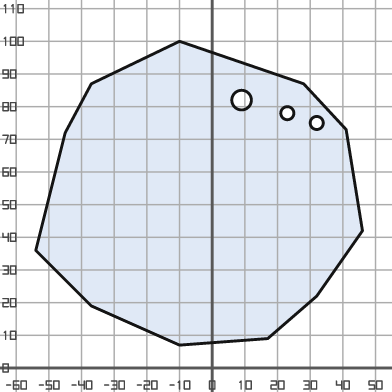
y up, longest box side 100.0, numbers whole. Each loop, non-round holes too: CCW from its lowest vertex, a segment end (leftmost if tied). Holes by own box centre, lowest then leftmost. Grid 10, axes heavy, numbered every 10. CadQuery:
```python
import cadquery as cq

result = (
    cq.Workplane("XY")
    .moveTo(-10.0, 7.0)
    .lineTo(17.0, 9.0)
    .lineTo(32.0, 22.0)
    .lineTo(46.0, 42.0)
    .lineTo(41.0, 73.0)
    .lineTo(28.0, 87.0)
    .lineTo(-10.0, 100.0)
    .lineTo(-37.0, 87.0)
    .lineTo(-45.0, 72.0)
    .lineTo(-54.0, 36.0)
    .lineTo(-37.0, 19.0)
    .close()
    .moveTo(32.0, 75.0)
    .circle(2.0)
    .moveTo(23.0, 78.0)
    .circle(2.0)
    .moveTo(9.0, 82.0)
    .circle(3.0)
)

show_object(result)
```